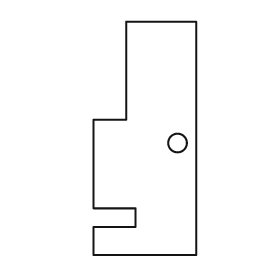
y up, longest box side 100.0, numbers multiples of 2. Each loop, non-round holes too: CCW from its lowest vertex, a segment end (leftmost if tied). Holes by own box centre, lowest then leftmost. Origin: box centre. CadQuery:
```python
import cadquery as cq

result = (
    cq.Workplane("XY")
    .moveTo(-22.0, -50.0)
    .lineTo(22.0, -50.0)
    .lineTo(22.0, 50.0)
    .lineTo(-8.0, 50.0)
    .lineTo(-8.0, 8.0)
    .lineTo(-22.0, 8.0)
    .lineTo(-22.0, -30.0)
    .lineTo(-4.0, -30.0)
    .lineTo(-4.0, -38.0)
    .lineTo(-22.0, -38.0)
    .close()
    .moveTo(14.0, -2.0)
    .circle(4.0)
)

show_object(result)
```